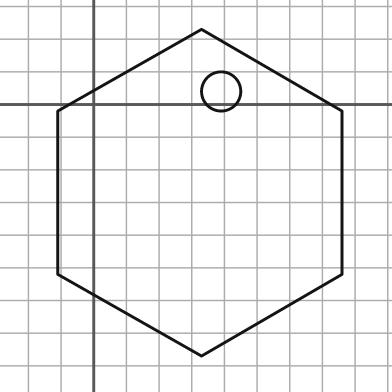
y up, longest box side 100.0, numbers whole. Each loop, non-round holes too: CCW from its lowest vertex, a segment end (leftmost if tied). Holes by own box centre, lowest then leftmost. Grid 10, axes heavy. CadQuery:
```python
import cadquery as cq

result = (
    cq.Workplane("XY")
    .moveTo(33.0, -77.0)
    .lineTo(76.0, -52.0)
    .lineTo(76.0, -2.0)
    .lineTo(33.0, 23.0)
    .lineTo(-11.0, -2.0)
    .lineTo(-11.0, -52.0)
    .close()
    .moveTo(39.0, 4.0)
    .circle(6.0)
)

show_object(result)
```